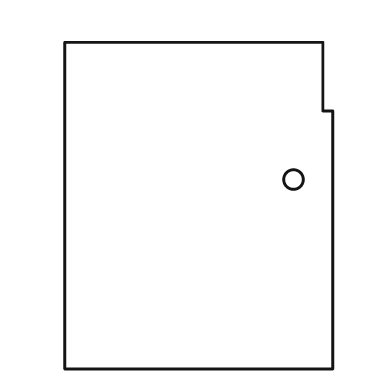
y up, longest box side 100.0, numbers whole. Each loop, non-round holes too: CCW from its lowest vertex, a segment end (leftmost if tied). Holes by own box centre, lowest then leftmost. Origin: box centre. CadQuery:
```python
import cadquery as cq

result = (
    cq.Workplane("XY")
    .moveTo(-41.0, -50.0)
    .lineTo(41.0, -50.0)
    .lineTo(41.0, 29.0)
    .lineTo(38.0, 29.0)
    .lineTo(38.0, 50.0)
    .lineTo(-41.0, 50.0)
    .close()
    .moveTo(29.0, 8.0)
    .circle(3.0)
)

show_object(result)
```